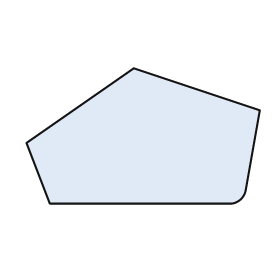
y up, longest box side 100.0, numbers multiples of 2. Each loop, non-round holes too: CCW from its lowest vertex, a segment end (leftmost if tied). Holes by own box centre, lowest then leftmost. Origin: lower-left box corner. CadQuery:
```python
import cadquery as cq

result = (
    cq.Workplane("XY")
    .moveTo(10.0, 0.0)
    .lineTo(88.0, 0.0)
    .threePointArc((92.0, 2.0), (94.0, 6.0))
    .lineTo(100.0, 40.0)
    .lineTo(46.0, 58.0)
    .lineTo(0.0, 26.0)
    .close()
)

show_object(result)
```